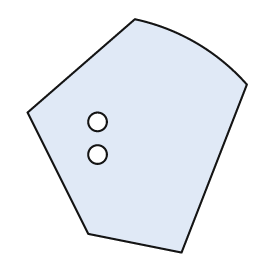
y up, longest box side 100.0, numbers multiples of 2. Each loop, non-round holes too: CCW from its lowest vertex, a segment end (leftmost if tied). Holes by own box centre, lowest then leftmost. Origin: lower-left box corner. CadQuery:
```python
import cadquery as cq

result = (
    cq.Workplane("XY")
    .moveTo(66.0, 0.0)
    .lineTo(94.0, 72.0)
    .threePointArc((72.0, 90.0), (46.0, 100.0))
    .lineTo(0.0, 60.0)
    .lineTo(26.0, 8.0)
    .close()
    .moveTo(30.0, 42.0)
    .circle(4.0)
    .moveTo(30.0, 56.0)
    .circle(4.0)
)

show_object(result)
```